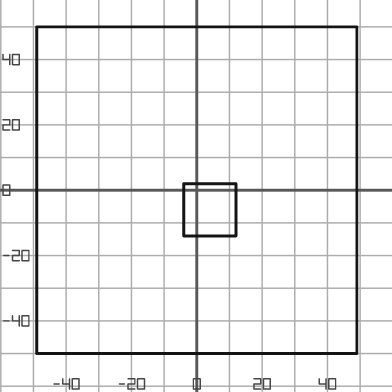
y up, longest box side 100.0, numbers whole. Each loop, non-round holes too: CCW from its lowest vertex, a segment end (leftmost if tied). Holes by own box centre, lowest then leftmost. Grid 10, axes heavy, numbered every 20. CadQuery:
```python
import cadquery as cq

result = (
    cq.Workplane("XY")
    .moveTo(-49.0, -50.0)
    .lineTo(49.0, -50.0)
    .lineTo(49.0, 50.0)
    .lineTo(-49.0, 50.0)
    .close()
    .moveTo(-4.0, -14.0)
    .lineTo(12.0, -14.0)
    .lineTo(12.0, 2.0)
    .lineTo(-4.0, 2.0)
    .close()
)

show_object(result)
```